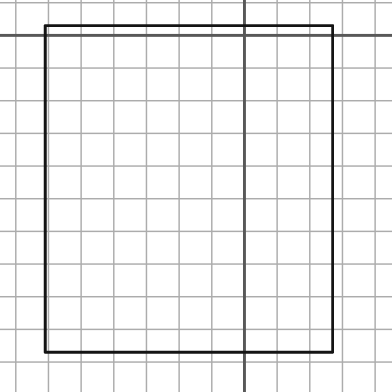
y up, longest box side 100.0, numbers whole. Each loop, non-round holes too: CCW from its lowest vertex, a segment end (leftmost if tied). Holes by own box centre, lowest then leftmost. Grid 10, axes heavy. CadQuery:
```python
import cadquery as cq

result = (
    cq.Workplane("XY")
    .moveTo(-61.0, -97.0)
    .lineTo(27.0, -97.0)
    .lineTo(27.0, 3.0)
    .lineTo(-61.0, 3.0)
    .close()
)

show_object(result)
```